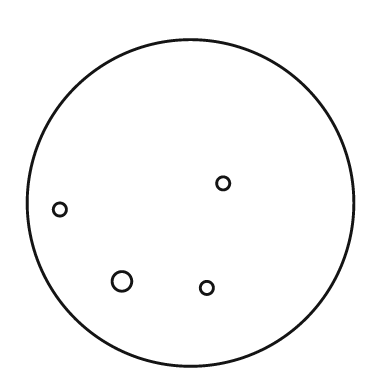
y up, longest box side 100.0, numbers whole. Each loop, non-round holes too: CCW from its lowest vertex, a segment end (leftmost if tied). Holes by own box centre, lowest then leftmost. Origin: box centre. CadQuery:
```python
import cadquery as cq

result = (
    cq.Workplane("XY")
    .moveTo(0.0, 0.0)
    .circle(50.0)
    .moveTo(5.0, -26.0)
    .circle(2.0)
    .moveTo(-21.0, -24.0)
    .circle(3.0)
    .moveTo(-40.0, -2.0)
    .circle(2.0)
    .moveTo(10.0, 6.0)
    .circle(2.0)
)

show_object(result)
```